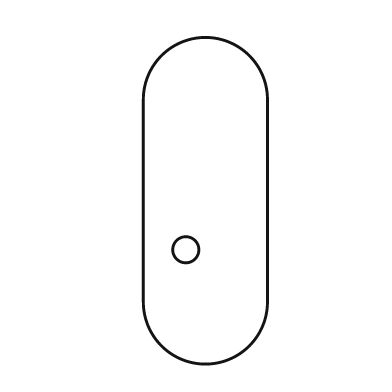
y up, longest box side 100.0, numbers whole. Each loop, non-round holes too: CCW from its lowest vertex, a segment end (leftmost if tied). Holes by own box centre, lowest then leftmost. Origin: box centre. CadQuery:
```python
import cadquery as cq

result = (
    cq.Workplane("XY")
    .moveTo(-19.0, -31.0)
    .threePointArc((0.0, -50.0), (19.0, -31.0))
    .lineTo(19.0, 31.0)
    .threePointArc((0.0, 50.0), (-19.0, 31.0))
    .close()
    .moveTo(-6.0, -15.0)
    .circle(4.0)
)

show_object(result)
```